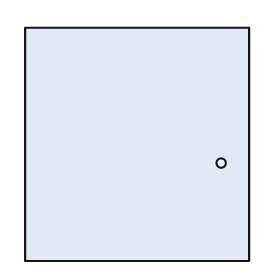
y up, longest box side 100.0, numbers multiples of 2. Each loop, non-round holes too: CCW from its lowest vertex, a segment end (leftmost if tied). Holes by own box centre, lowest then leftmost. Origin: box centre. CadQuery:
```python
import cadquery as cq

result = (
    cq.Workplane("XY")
    .moveTo(-48.0, -50.0)
    .lineTo(48.0, -50.0)
    .lineTo(48.0, 50.0)
    .lineTo(-48.0, 50.0)
    .close()
    .moveTo(36.0, -8.0)
    .circle(2.0)
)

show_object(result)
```